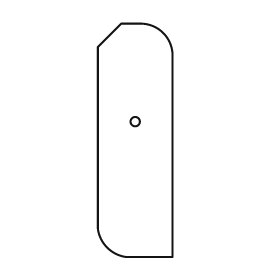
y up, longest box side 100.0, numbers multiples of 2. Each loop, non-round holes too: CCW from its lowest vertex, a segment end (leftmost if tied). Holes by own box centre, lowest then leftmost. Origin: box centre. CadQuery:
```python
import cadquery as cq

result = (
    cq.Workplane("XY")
    .moveTo(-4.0, -50.0)
    .lineTo(16.0, -50.0)
    .lineTo(16.0, 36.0)
    .threePointArc((12.0, 46.0), (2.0, 50.0))
    .lineTo(-6.0, 50.0)
    .lineTo(-16.0, 40.0)
    .lineTo(-16.0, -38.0)
    .threePointArc((-12.0, -46.0), (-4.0, -50.0))
    .close()
    .moveTo(0.0, 8.0)
    .circle(2.0)
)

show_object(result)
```